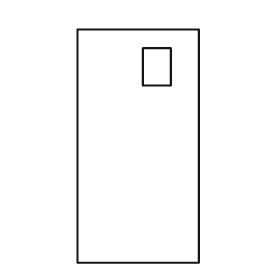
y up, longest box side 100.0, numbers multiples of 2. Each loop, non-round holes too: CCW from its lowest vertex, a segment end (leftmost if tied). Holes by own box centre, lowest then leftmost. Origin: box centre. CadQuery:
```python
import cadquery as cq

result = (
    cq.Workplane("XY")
    .moveTo(-26.0, -50.0)
    .lineTo(26.0, -50.0)
    .lineTo(26.0, 50.0)
    .lineTo(-26.0, 50.0)
    .close()
    .moveTo(2.0, 26.0)
    .lineTo(14.0, 26.0)
    .lineTo(14.0, 42.0)
    .lineTo(2.0, 42.0)
    .close()
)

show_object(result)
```